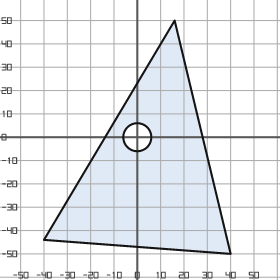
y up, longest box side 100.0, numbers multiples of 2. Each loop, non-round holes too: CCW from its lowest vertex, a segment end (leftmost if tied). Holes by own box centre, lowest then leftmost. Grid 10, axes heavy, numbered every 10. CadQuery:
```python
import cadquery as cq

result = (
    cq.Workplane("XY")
    .moveTo(40.0, -50.0)
    .lineTo(16.0, 50.0)
    .lineTo(-40.0, -44.0)
    .close()
    .moveTo(0.0, 0.0)
    .circle(6.0)
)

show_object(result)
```